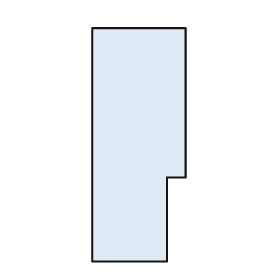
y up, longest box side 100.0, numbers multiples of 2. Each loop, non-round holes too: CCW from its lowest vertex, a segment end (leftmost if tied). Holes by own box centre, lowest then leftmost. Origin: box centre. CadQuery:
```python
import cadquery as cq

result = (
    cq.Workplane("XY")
    .moveTo(-20.0, -50.0)
    .lineTo(12.0, -50.0)
    .lineTo(12.0, -14.0)
    .lineTo(20.0, -14.0)
    .lineTo(20.0, 50.0)
    .lineTo(-20.0, 50.0)
    .close()
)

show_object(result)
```